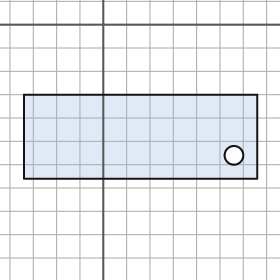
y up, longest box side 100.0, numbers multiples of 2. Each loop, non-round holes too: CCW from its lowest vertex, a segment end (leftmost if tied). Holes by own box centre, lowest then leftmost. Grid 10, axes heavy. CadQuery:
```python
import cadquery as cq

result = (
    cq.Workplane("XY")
    .moveTo(-34.0, -66.0)
    .lineTo(66.0, -66.0)
    .lineTo(66.0, -30.0)
    .lineTo(-34.0, -30.0)
    .close()
    .moveTo(56.0, -56.0)
    .circle(4.0)
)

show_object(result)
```